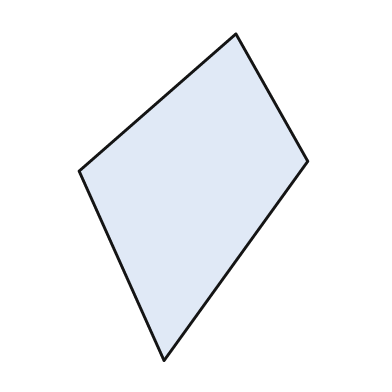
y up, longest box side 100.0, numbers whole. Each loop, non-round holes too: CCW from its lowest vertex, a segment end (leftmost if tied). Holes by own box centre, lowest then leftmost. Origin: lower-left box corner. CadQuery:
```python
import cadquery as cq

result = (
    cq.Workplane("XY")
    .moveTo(26.0, 0.0)
    .lineTo(70.0, 61.0)
    .lineTo(48.0, 100.0)
    .lineTo(0.0, 58.0)
    .close()
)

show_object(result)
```